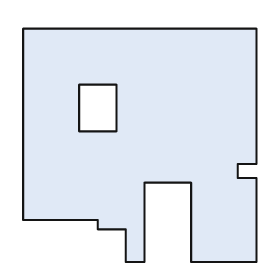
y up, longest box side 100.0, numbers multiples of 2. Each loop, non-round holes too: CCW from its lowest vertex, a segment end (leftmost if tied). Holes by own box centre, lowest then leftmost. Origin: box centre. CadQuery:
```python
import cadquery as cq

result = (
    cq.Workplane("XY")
    .moveTo(-6.0, -50.0)
    .lineTo(2.0, -50.0)
    .lineTo(2.0, -16.0)
    .lineTo(22.0, -16.0)
    .lineTo(22.0, -50.0)
    .lineTo(50.0, -50.0)
    .lineTo(50.0, -14.0)
    .lineTo(42.0, -14.0)
    .lineTo(42.0, -8.0)
    .lineTo(50.0, -8.0)
    .lineTo(50.0, 50.0)
    .lineTo(-50.0, 50.0)
    .lineTo(-50.0, -32.0)
    .lineTo(-18.0, -32.0)
    .lineTo(-18.0, -36.0)
    .lineTo(-6.0, -36.0)
    .close()
    .moveTo(-26.0, 6.0)
    .lineTo(-10.0, 6.0)
    .lineTo(-10.0, 26.0)
    .lineTo(-26.0, 26.0)
    .close()
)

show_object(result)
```